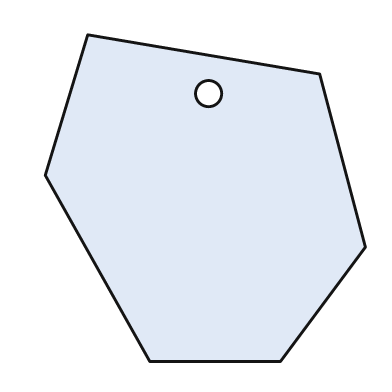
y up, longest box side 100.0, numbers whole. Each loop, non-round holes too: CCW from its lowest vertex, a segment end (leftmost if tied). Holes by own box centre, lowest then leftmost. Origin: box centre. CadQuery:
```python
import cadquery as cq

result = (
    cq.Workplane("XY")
    .moveTo(-17.0, -50.0)
    .lineTo(23.0, -50.0)
    .lineTo(49.0, -15.0)
    .lineTo(35.0, 38.0)
    .lineTo(-36.0, 50.0)
    .lineTo(-49.0, 7.0)
    .close()
    .moveTo(1.0, 32.0)
    .circle(4.0)
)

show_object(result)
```